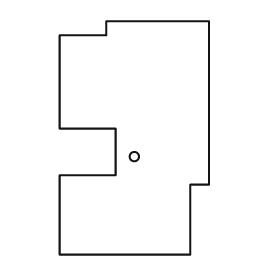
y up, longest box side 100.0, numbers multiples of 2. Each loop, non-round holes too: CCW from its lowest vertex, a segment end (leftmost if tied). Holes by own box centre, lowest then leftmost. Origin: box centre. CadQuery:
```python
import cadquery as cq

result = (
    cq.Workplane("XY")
    .moveTo(-32.0, -50.0)
    .lineTo(24.0, -50.0)
    .lineTo(24.0, -20.0)
    .lineTo(32.0, -20.0)
    .lineTo(32.0, 50.0)
    .lineTo(-12.0, 50.0)
    .lineTo(-12.0, 44.0)
    .lineTo(-32.0, 44.0)
    .lineTo(-32.0, 4.0)
    .lineTo(-8.0, 4.0)
    .lineTo(-8.0, -16.0)
    .lineTo(-32.0, -16.0)
    .close()
    .moveTo(0.0, -8.0)
    .circle(2.0)
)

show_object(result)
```